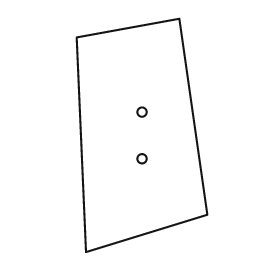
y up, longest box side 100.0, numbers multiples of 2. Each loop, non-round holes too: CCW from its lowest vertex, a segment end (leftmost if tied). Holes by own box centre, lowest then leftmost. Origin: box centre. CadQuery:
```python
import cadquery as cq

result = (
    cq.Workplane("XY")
    .moveTo(-24.0, -50.0)
    .lineTo(28.0, -34.0)
    .lineTo(16.0, 50.0)
    .lineTo(-28.0, 42.0)
    .close()
    .moveTo(0.0, -10.0)
    .circle(2.0)
    .moveTo(0.0, 10.0)
    .circle(2.0)
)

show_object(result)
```